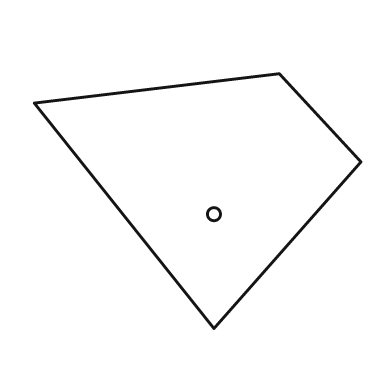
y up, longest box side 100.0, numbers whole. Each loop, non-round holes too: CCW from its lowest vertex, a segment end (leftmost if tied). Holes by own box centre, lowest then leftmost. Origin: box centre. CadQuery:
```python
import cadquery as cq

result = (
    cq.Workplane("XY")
    .moveTo(5.0, -39.0)
    .lineTo(50.0, 12.0)
    .lineTo(25.0, 39.0)
    .lineTo(-50.0, 30.0)
    .close()
    .moveTo(5.0, -4.0)
    .circle(2.0)
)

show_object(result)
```